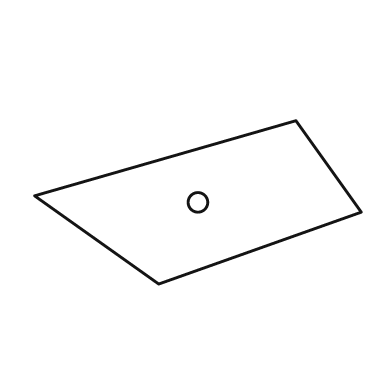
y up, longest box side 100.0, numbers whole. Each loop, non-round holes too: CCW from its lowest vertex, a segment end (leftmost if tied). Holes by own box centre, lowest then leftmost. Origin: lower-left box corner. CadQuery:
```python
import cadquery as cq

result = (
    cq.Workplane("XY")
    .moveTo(38.0, 0.0)
    .lineTo(100.0, 22.0)
    .lineTo(80.0, 50.0)
    .lineTo(0.0, 27.0)
    .close()
    .moveTo(50.0, 25.0)
    .circle(3.0)
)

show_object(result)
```